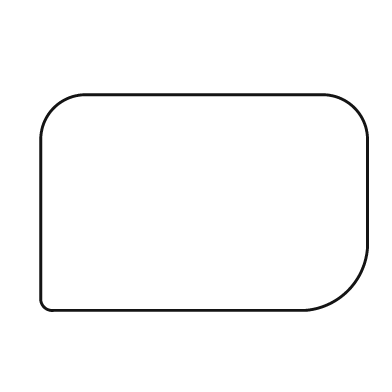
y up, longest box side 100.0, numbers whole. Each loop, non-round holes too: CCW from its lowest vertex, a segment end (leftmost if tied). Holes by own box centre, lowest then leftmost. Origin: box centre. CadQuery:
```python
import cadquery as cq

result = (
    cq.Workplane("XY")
    .moveTo(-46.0, -33.0)
    .lineTo(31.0, -33.0)
    .threePointArc((44.0, -27.0), (50.0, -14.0))
    .lineTo(50.0, 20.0)
    .threePointArc((46.0, 29.0), (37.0, 33.0))
    .lineTo(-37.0, 33.0)
    .threePointArc((-46.0, 29.0), (-50.0, 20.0))
    .lineTo(-50.0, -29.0)
    .threePointArc((-49.0, -32.0), (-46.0, -33.0))
    .close()
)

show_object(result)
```